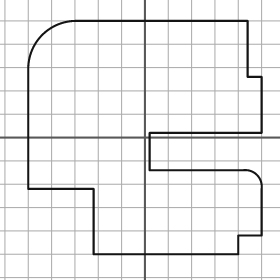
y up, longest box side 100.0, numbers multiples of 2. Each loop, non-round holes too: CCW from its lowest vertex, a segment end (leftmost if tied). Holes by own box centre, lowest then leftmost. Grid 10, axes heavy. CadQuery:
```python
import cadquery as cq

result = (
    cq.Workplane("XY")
    .moveTo(-22.0, -50.0)
    .lineTo(40.0, -50.0)
    .lineTo(40.0, -42.0)
    .lineTo(50.0, -42.0)
    .lineTo(50.0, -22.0)
    .threePointArc((48.0, -16.0), (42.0, -14.0))
    .lineTo(2.0, -14.0)
    .lineTo(2.0, 2.0)
    .lineTo(50.0, 2.0)
    .lineTo(50.0, 26.0)
    .lineTo(44.0, 26.0)
    .lineTo(44.0, 50.0)
    .lineTo(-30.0, 50.0)
    .threePointArc((-44.0, 44.0), (-50.0, 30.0))
    .lineTo(-50.0, -22.0)
    .lineTo(-22.0, -22.0)
    .close()
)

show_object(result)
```